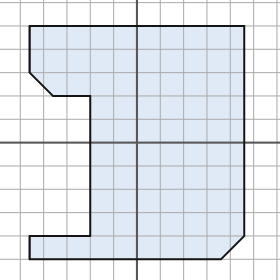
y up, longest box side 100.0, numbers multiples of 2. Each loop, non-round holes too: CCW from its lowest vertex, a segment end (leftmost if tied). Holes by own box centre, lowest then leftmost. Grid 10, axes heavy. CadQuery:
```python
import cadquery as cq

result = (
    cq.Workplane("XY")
    .moveTo(-46.0, -50.0)
    .lineTo(36.0, -50.0)
    .lineTo(46.0, -40.0)
    .lineTo(46.0, 50.0)
    .lineTo(-46.0, 50.0)
    .lineTo(-46.0, 30.0)
    .lineTo(-36.0, 20.0)
    .lineTo(-20.0, 20.0)
    .lineTo(-20.0, -40.0)
    .lineTo(-46.0, -40.0)
    .close()
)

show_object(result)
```